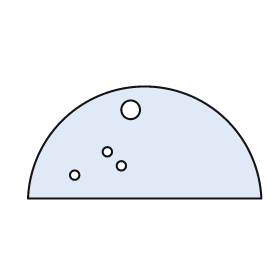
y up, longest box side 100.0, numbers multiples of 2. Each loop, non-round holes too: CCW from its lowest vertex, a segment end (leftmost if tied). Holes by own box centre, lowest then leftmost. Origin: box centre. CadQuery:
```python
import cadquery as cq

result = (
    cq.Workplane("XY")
    .moveTo(-50.0, -24.0)
    .lineTo(50.0, -24.0)
    .threePointArc((0.0, 24.0), (-50.0, -24.0))
    .close()
    .moveTo(-30.0, -14.0)
    .circle(2.0)
    .moveTo(-10.0, -10.0)
    .circle(2.0)
    .moveTo(-16.0, -4.0)
    .circle(2.0)
    .moveTo(-6.0, 14.0)
    .circle(4.0)
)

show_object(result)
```